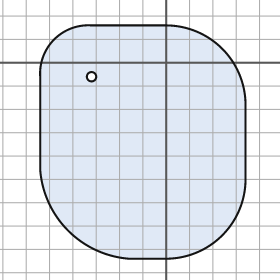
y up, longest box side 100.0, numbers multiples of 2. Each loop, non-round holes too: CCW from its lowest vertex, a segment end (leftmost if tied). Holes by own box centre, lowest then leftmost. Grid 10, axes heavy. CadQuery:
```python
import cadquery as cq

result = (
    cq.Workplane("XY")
    .moveTo(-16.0, -84.0)
    .lineTo(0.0, -84.0)
    .threePointArc((24.0, -74.0), (34.0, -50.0))
    .lineTo(34.0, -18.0)
    .threePointArc((24.0, 6.0), (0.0, 16.0))
    .lineTo(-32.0, 16.0)
    .threePointArc((-48.0, 10.0), (-54.0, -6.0))
    .lineTo(-54.0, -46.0)
    .threePointArc((-42.0, -72.0), (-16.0, -84.0))
    .close()
    .moveTo(-32.0, -6.0)
    .circle(2.0)
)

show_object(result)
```